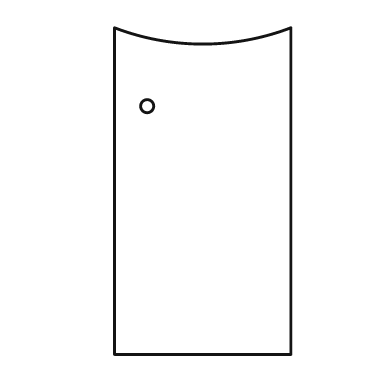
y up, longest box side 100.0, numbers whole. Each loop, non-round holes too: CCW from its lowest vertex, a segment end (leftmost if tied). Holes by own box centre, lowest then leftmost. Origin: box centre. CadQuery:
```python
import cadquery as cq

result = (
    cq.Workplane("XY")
    .moveTo(-27.0, -50.0)
    .lineTo(27.0, -50.0)
    .lineTo(27.0, 50.0)
    .threePointArc((0.0, 45.0), (-27.0, 50.0))
    .close()
    .moveTo(-17.0, 26.0)
    .circle(2.0)
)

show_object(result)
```